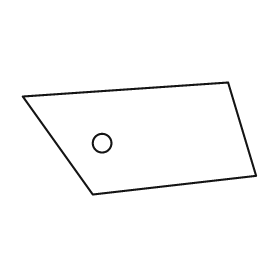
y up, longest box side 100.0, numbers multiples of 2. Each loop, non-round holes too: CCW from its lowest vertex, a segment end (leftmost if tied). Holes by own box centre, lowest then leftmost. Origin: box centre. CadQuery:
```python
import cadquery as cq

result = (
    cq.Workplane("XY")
    .moveTo(-20.0, -24.0)
    .lineTo(50.0, -16.0)
    .lineTo(38.0, 24.0)
    .lineTo(-50.0, 18.0)
    .close()
    .moveTo(-16.0, -2.0)
    .circle(4.0)
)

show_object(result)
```